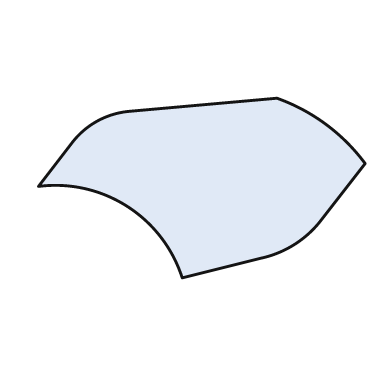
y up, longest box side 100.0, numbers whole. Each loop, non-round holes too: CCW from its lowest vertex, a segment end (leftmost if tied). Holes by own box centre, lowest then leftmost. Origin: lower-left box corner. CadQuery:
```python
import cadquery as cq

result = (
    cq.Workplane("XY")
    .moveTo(44.0, 0.0)
    .lineTo(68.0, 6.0)
    .threePointArc((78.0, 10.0), (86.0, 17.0))
    .lineTo(100.0, 35.0)
    .threePointArc((88.0, 47.0), (73.0, 55.0))
    .lineTo(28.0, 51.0)
    .threePointArc((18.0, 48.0), (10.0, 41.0))
    .lineTo(0.0, 28.0)
    .threePointArc((27.0, 22.0), (44.0, 0.0))
    .close()
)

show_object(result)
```